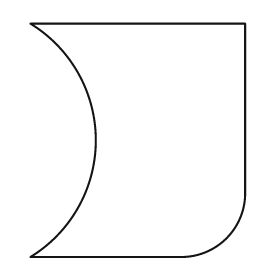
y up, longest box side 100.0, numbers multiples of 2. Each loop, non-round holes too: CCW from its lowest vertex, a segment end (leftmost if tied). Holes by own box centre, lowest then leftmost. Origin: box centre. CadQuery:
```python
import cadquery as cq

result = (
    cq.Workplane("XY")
    .moveTo(-46.0, -50.0)
    .lineTo(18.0, -50.0)
    .threePointArc((38.0, -42.0), (46.0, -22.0))
    .lineTo(46.0, 50.0)
    .lineTo(-46.0, 50.0)
    .threePointArc((-18.0, 0.0), (-46.0, -50.0))
    .close()
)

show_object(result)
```